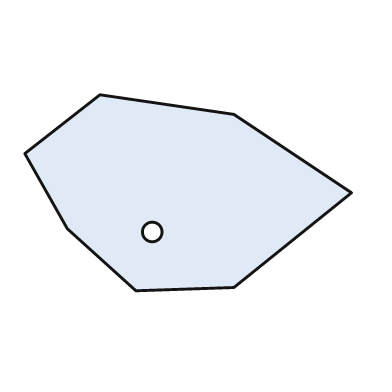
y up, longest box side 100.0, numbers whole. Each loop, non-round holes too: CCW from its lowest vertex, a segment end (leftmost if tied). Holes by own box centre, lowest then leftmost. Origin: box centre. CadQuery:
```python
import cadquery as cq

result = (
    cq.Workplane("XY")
    .moveTo(-16.0, -30.0)
    .lineTo(14.0, -29.0)
    .lineTo(50.0, 0.0)
    .lineTo(14.0, 24.0)
    .lineTo(-27.0, 30.0)
    .lineTo(-50.0, 12.0)
    .lineTo(-37.0, -11.0)
    .close()
    .moveTo(-11.0, -12.0)
    .circle(3.0)
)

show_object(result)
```